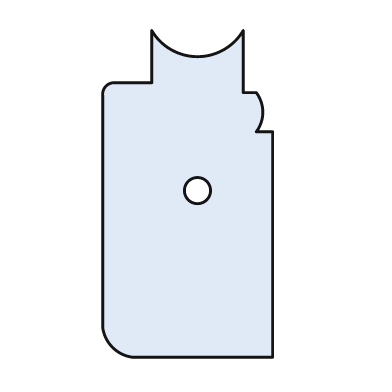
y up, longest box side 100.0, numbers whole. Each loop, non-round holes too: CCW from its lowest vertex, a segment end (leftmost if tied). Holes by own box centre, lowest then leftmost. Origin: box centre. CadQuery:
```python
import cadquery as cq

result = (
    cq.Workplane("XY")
    .moveTo(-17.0, -50.0)
    .lineTo(26.0, -50.0)
    .lineTo(26.0, 19.0)
    .lineTo(21.0, 19.0)
    .threePointArc((23.0, 25.0), (21.0, 31.0))
    .lineTo(17.0, 31.0)
    .lineTo(17.0, 50.0)
    .threePointArc((3.0, 42.0), (-11.0, 50.0))
    .lineTo(-11.0, 34.0)
    .lineTo(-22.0, 34.0)
    .threePointArc((-25.0, 33.0), (-26.0, 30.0))
    .lineTo(-26.0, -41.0)
    .threePointArc((-23.0, -47.0), (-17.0, -50.0))
    .close()
    .moveTo(3.0, 1.0)
    .circle(4.0)
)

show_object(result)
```